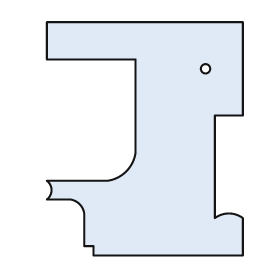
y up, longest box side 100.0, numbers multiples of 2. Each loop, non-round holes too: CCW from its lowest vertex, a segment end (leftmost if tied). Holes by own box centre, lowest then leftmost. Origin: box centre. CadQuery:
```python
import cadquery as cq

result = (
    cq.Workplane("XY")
    .moveTo(-22.0, -50.0)
    .lineTo(42.0, -50.0)
    .lineTo(42.0, -34.0)
    .threePointArc((36.0, -32.0), (30.0, -34.0))
    .lineTo(30.0, 10.0)
    .lineTo(42.0, 10.0)
    .lineTo(42.0, 50.0)
    .lineTo(-42.0, 50.0)
    .lineTo(-42.0, 34.0)
    .lineTo(-4.0, 34.0)
    .lineTo(-4.0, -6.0)
    .threePointArc((-8.0, -14.0), (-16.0, -18.0))
    .lineTo(-42.0, -18.0)
    .threePointArc((-40.0, -22.0), (-42.0, -26.0))
    .lineTo(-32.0, -26.0)
    .threePointArc((-28.0, -28.0), (-26.0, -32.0))
    .lineTo(-26.0, -46.0)
    .lineTo(-22.0, -46.0)
    .close()
    .moveTo(26.0, 30.0)
    .circle(2.0)
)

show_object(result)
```